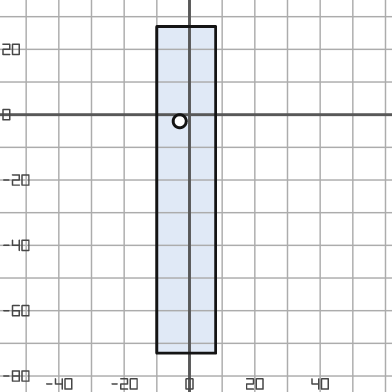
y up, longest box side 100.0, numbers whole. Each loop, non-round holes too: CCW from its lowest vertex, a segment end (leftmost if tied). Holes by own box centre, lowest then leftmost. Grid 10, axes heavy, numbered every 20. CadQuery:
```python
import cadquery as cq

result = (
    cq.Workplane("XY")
    .moveTo(-10.0, -73.0)
    .lineTo(8.0, -73.0)
    .lineTo(8.0, 27.0)
    .lineTo(-10.0, 27.0)
    .close()
    .moveTo(-3.0, -2.0)
    .circle(2.0)
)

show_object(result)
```